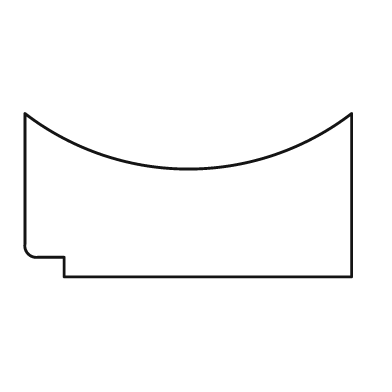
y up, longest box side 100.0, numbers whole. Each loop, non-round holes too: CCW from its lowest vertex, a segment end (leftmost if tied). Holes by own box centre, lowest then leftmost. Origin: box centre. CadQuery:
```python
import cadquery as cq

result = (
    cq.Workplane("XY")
    .moveTo(-38.0, -25.0)
    .lineTo(50.0, -25.0)
    .lineTo(50.0, 25.0)
    .threePointArc((0.0, 8.0), (-50.0, 25.0))
    .lineTo(-50.0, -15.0)
    .threePointArc((-49.0, -18.0), (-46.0, -19.0))
    .lineTo(-38.0, -19.0)
    .close()
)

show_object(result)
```